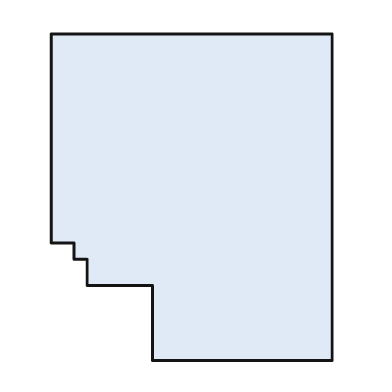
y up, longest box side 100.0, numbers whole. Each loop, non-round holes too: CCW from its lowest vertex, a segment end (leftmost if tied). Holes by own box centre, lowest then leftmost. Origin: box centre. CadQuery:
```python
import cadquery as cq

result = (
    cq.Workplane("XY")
    .moveTo(-12.0, -50.0)
    .lineTo(43.0, -50.0)
    .lineTo(43.0, 50.0)
    .lineTo(-43.0, 50.0)
    .lineTo(-43.0, -14.0)
    .lineTo(-36.0, -14.0)
    .lineTo(-36.0, -19.0)
    .lineTo(-32.0, -19.0)
    .lineTo(-32.0, -27.0)
    .lineTo(-12.0, -27.0)
    .close()
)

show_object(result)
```